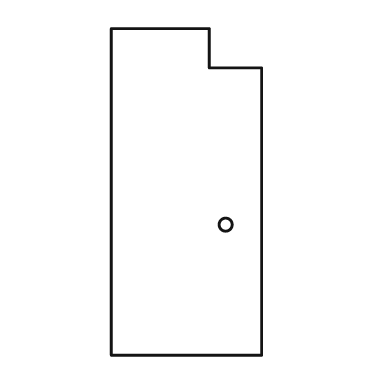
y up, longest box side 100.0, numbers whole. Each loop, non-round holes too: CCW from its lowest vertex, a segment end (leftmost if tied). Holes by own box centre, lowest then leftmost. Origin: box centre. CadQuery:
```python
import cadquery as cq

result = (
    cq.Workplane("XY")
    .moveTo(-23.0, -50.0)
    .lineTo(23.0, -50.0)
    .lineTo(23.0, 38.0)
    .lineTo(7.0, 38.0)
    .lineTo(7.0, 50.0)
    .lineTo(-23.0, 50.0)
    .close()
    .moveTo(12.0, -10.0)
    .circle(2.0)
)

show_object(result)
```